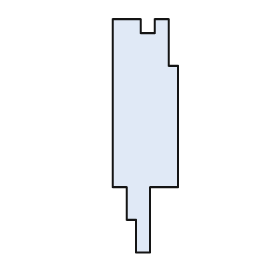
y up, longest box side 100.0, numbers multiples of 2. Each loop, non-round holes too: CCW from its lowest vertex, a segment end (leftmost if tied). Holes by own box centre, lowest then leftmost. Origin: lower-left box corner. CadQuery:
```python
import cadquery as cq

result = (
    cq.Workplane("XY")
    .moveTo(10.0, 0.0)
    .lineTo(16.0, 0.0)
    .lineTo(16.0, 28.0)
    .lineTo(28.0, 28.0)
    .lineTo(28.0, 80.0)
    .lineTo(24.0, 80.0)
    .lineTo(24.0, 100.0)
    .lineTo(18.0, 100.0)
    .lineTo(18.0, 94.0)
    .lineTo(12.0, 94.0)
    .lineTo(12.0, 100.0)
    .lineTo(0.0, 100.0)
    .lineTo(0.0, 28.0)
    .lineTo(6.0, 28.0)
    .lineTo(6.0, 14.0)
    .lineTo(10.0, 14.0)
    .close()
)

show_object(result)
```